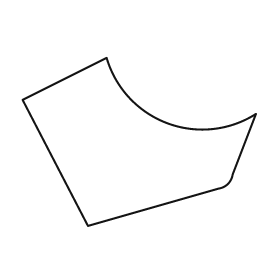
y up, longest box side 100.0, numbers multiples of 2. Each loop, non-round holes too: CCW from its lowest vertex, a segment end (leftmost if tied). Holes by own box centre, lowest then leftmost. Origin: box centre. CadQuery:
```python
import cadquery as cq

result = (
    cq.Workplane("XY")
    .moveTo(-22.0, -36.0)
    .lineTo(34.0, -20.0)
    .threePointArc((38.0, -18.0), (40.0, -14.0))
    .lineTo(50.0, 12.0)
    .threePointArc((12.0, 8.0), (-14.0, 36.0))
    .lineTo(-50.0, 18.0)
    .close()
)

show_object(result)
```